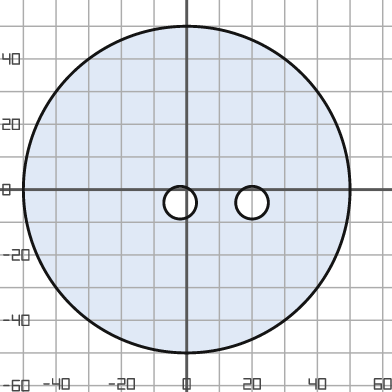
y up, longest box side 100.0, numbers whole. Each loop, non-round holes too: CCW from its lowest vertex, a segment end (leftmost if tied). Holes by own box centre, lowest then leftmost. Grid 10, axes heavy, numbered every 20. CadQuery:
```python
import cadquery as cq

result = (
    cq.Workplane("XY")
    .moveTo(0.0, 0.0)
    .circle(50.0)
    .moveTo(-2.0, -4.0)
    .circle(5.0)
    .moveTo(20.0, -4.0)
    .circle(5.0)
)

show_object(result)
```